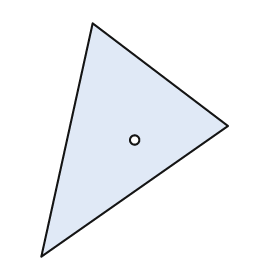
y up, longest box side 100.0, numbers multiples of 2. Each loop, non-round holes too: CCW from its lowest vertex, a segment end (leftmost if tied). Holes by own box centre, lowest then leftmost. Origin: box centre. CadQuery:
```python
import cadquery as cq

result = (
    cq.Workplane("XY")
    .moveTo(-40.0, -50.0)
    .lineTo(40.0, 6.0)
    .lineTo(-18.0, 50.0)
    .close()
    .moveTo(0.0, 0.0)
    .circle(2.0)
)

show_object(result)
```